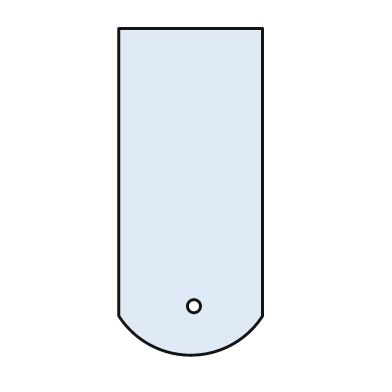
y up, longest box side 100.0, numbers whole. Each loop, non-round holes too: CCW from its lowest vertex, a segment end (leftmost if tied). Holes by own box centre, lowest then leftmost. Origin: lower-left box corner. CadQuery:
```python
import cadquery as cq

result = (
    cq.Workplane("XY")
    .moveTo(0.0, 12.0)
    .threePointArc((22.0, 0.0), (44.0, 12.0))
    .lineTo(44.0, 100.0)
    .lineTo(0.0, 100.0)
    .close()
    .moveTo(23.0, 15.0)
    .circle(2.0)
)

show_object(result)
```